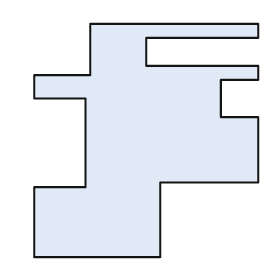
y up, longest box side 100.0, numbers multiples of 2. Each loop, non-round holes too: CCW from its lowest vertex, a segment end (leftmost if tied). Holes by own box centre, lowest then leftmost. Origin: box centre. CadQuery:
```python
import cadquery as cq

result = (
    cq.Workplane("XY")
    .moveTo(-48.0, -50.0)
    .lineTo(6.0, -50.0)
    .lineTo(6.0, -18.0)
    .lineTo(48.0, -18.0)
    .lineTo(48.0, 10.0)
    .lineTo(32.0, 10.0)
    .lineTo(32.0, 26.0)
    .lineTo(48.0, 26.0)
    .lineTo(48.0, 32.0)
    .lineTo(0.0, 32.0)
    .lineTo(0.0, 44.0)
    .lineTo(48.0, 44.0)
    .lineTo(48.0, 50.0)
    .lineTo(-24.0, 50.0)
    .lineTo(-24.0, 28.0)
    .lineTo(-48.0, 28.0)
    .lineTo(-48.0, 18.0)
    .lineTo(-26.0, 18.0)
    .lineTo(-26.0, -20.0)
    .lineTo(-48.0, -20.0)
    .close()
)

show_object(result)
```